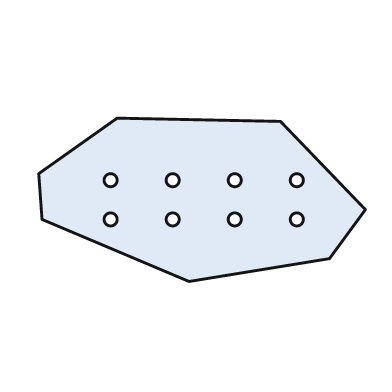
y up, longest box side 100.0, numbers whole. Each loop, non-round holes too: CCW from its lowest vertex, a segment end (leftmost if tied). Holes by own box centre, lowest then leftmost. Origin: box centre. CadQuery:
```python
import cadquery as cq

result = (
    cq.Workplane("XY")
    .moveTo(-4.0, -25.0)
    .lineTo(39.0, -18.0)
    .lineTo(50.0, -3.0)
    .lineTo(24.0, 24.0)
    .lineTo(-26.0, 25.0)
    .lineTo(-50.0, 8.0)
    .lineTo(-49.0, -6.0)
    .close()
    .moveTo(-28.0, -6.0)
    .circle(2.0)
    .moveTo(-9.0, -6.0)
    .circle(2.0)
    .moveTo(10.0, -6.0)
    .circle(2.0)
    .moveTo(29.0, -6.0)
    .circle(2.0)
    .moveTo(-28.0, 6.0)
    .circle(2.0)
    .moveTo(-9.0, 6.0)
    .circle(2.0)
    .moveTo(10.0, 6.0)
    .circle(2.0)
    .moveTo(29.0, 6.0)
    .circle(2.0)
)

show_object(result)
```